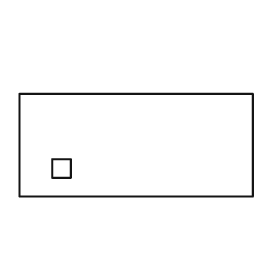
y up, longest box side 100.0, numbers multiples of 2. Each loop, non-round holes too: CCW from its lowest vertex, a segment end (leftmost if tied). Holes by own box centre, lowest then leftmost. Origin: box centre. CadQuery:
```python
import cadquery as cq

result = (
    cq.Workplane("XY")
    .moveTo(-50.0, -22.0)
    .lineTo(50.0, -22.0)
    .lineTo(50.0, 22.0)
    .lineTo(-50.0, 22.0)
    .close()
    .moveTo(-36.0, -14.0)
    .lineTo(-28.0, -14.0)
    .lineTo(-28.0, -6.0)
    .lineTo(-36.0, -6.0)
    .close()
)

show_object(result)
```